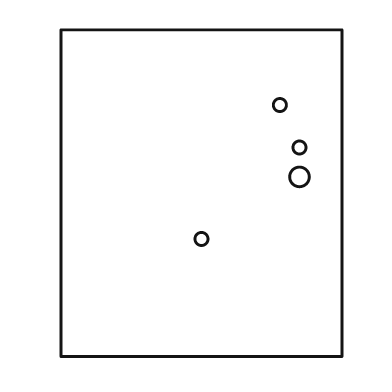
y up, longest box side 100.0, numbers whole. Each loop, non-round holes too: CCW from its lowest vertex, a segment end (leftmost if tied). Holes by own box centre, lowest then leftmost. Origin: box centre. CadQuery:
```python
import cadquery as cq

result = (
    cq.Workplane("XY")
    .moveTo(-43.0, -50.0)
    .lineTo(43.0, -50.0)
    .lineTo(43.0, 50.0)
    .lineTo(-43.0, 50.0)
    .close()
    .moveTo(0.0, -14.0)
    .circle(2.0)
    .moveTo(30.0, 5.0)
    .circle(3.0)
    .moveTo(30.0, 14.0)
    .circle(2.0)
    .moveTo(24.0, 27.0)
    .circle(2.0)
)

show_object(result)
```